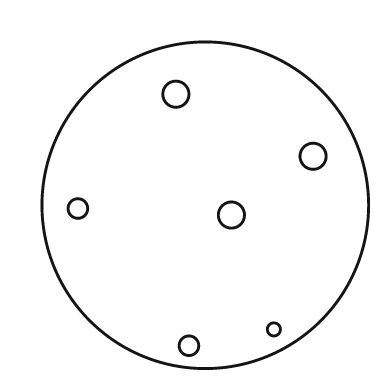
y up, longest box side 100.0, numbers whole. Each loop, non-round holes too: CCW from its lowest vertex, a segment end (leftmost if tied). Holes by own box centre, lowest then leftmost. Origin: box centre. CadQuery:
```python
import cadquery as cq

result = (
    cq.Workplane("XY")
    .moveTo(0.0, 0.0)
    .circle(50.0)
    .moveTo(-5.0, -43.0)
    .circle(3.0)
    .moveTo(21.0, -38.0)
    .circle(2.0)
    .moveTo(8.0, -3.0)
    .circle(4.0)
    .moveTo(-39.0, -1.0)
    .circle(3.0)
    .moveTo(33.0, 15.0)
    .circle(4.0)
    .moveTo(-9.0, 34.0)
    .circle(4.0)
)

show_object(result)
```